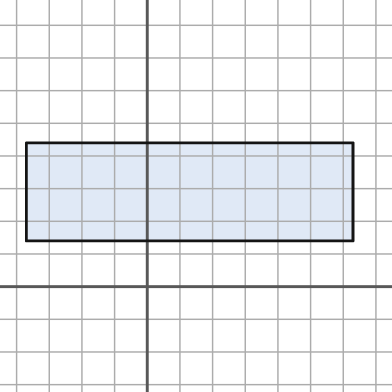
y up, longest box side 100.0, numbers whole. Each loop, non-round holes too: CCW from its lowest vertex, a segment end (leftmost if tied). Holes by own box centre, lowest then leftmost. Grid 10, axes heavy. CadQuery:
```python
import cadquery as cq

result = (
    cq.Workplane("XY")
    .moveTo(-37.0, 14.0)
    .lineTo(63.0, 14.0)
    .lineTo(63.0, 44.0)
    .lineTo(-37.0, 44.0)
    .close()
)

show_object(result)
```